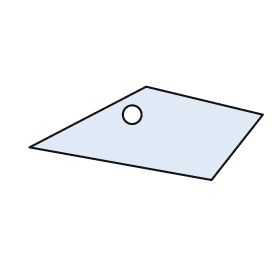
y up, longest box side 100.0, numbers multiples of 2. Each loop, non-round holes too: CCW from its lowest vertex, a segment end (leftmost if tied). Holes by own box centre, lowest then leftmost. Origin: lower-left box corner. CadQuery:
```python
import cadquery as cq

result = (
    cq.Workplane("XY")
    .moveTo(78.0, 0.0)
    .lineTo(100.0, 28.0)
    .lineTo(50.0, 40.0)
    .lineTo(0.0, 14.0)
    .close()
    .moveTo(44.0, 28.0)
    .circle(4.0)
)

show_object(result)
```